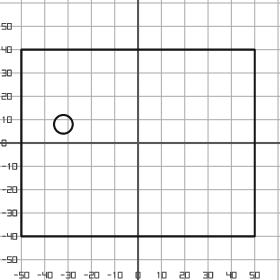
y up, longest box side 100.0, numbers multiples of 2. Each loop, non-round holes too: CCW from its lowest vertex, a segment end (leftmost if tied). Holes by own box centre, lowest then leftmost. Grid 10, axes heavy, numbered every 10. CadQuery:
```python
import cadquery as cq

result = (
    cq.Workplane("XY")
    .moveTo(-50.0, -40.0)
    .lineTo(50.0, -40.0)
    .lineTo(50.0, 40.0)
    .lineTo(-50.0, 40.0)
    .close()
    .moveTo(-32.0, 8.0)
    .circle(4.0)
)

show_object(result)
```